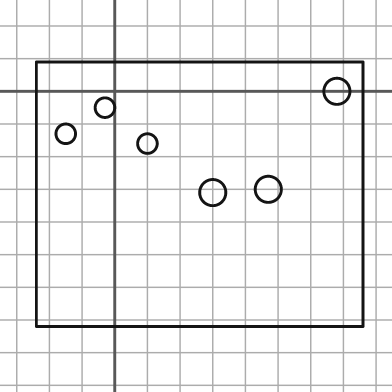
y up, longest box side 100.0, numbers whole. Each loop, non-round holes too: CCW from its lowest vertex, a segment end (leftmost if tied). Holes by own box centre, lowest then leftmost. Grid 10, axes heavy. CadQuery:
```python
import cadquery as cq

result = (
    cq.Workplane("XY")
    .moveTo(-24.0, -72.0)
    .lineTo(76.0, -72.0)
    .lineTo(76.0, 9.0)
    .lineTo(-24.0, 9.0)
    .close()
    .moveTo(30.0, -31.0)
    .circle(4.0)
    .moveTo(47.0, -30.0)
    .circle(4.0)
    .moveTo(10.0, -16.0)
    .circle(3.0)
    .moveTo(-15.0, -13.0)
    .circle(3.0)
    .moveTo(-3.0, -5.0)
    .circle(3.0)
    .moveTo(68.0, 0.0)
    .circle(4.0)
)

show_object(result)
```